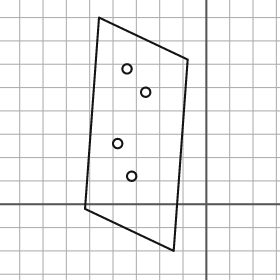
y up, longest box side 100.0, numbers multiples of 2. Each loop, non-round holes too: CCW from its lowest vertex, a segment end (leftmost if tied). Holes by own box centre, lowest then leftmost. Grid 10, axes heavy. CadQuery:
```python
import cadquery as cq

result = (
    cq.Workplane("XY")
    .moveTo(-14.0, -20.0)
    .lineTo(-8.0, 62.0)
    .lineTo(-46.0, 80.0)
    .lineTo(-52.0, -2.0)
    .close()
    .moveTo(-32.0, 12.0)
    .circle(2.0)
    .moveTo(-38.0, 26.0)
    .circle(2.0)
    .moveTo(-26.0, 48.0)
    .circle(2.0)
    .moveTo(-34.0, 58.0)
    .circle(2.0)
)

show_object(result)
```